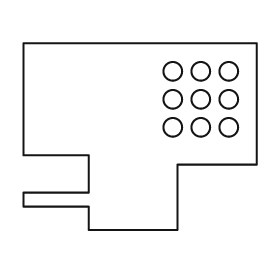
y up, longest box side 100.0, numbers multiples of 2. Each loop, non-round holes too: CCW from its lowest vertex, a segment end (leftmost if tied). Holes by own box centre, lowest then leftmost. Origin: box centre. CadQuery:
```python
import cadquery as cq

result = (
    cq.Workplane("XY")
    .moveTo(-22.0, -40.0)
    .lineTo(16.0, -40.0)
    .lineTo(16.0, -12.0)
    .lineTo(50.0, -12.0)
    .lineTo(50.0, 40.0)
    .lineTo(-50.0, 40.0)
    .lineTo(-50.0, -8.0)
    .lineTo(-22.0, -8.0)
    .lineTo(-22.0, -24.0)
    .lineTo(-50.0, -24.0)
    .lineTo(-50.0, -30.0)
    .lineTo(-22.0, -30.0)
    .close()
    .moveTo(14.0, 4.0)
    .circle(4.0)
    .moveTo(26.0, 4.0)
    .circle(4.0)
    .moveTo(38.0, 4.0)
    .circle(4.0)
    .moveTo(14.0, 16.0)
    .circle(4.0)
    .moveTo(26.0, 16.0)
    .circle(4.0)
    .moveTo(38.0, 16.0)
    .circle(4.0)
    .moveTo(14.0, 28.0)
    .circle(4.0)
    .moveTo(26.0, 28.0)
    .circle(4.0)
    .moveTo(38.0, 28.0)
    .circle(4.0)
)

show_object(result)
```